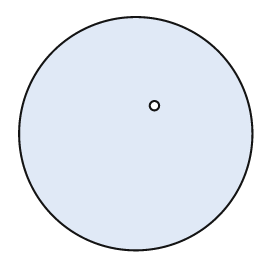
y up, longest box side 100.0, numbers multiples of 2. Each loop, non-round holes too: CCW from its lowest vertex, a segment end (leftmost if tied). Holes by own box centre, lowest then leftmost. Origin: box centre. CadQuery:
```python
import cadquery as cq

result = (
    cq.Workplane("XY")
    .moveTo(0.0, 0.0)
    .circle(50.0)
    .moveTo(8.0, 12.0)
    .circle(2.0)
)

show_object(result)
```